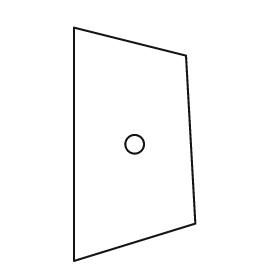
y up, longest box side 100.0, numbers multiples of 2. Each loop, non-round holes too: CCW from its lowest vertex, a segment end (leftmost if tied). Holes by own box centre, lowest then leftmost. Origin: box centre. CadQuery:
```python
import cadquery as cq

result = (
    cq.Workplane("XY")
    .moveTo(-26.0, -50.0)
    .lineTo(26.0, -34.0)
    .lineTo(22.0, 38.0)
    .lineTo(-26.0, 50.0)
    .close()
    .moveTo(0.0, 0.0)
    .circle(4.0)
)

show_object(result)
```